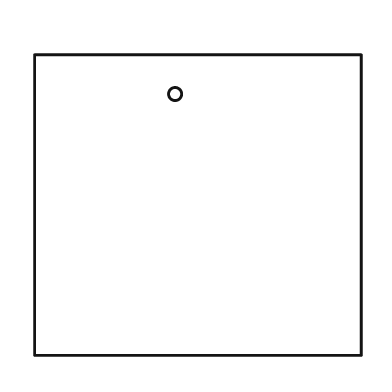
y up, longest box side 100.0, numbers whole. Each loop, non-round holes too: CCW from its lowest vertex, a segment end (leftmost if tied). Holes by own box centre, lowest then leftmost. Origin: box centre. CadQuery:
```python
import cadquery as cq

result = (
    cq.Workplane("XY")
    .moveTo(-50.0, -46.0)
    .lineTo(50.0, -46.0)
    .lineTo(50.0, 46.0)
    .lineTo(-50.0, 46.0)
    .close()
    .moveTo(-7.0, 34.0)
    .circle(2.0)
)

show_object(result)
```